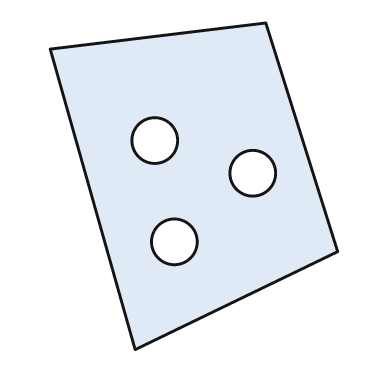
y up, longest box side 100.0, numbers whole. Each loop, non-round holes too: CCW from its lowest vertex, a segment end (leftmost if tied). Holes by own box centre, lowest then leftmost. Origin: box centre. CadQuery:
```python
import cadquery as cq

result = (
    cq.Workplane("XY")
    .moveTo(-18.0, -50.0)
    .lineTo(44.0, -20.0)
    .lineTo(22.0, 50.0)
    .lineTo(-44.0, 42.0)
    .close()
    .moveTo(-6.0, -17.0)
    .circle(7.0)
    .moveTo(18.0, 4.0)
    .circle(7.0)
    .moveTo(-12.0, 14.0)
    .circle(7.0)
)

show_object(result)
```